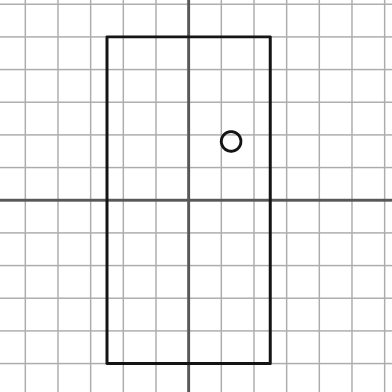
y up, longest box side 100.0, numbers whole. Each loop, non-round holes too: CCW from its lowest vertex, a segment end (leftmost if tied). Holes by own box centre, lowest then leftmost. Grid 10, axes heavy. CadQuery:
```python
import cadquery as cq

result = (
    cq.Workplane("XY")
    .moveTo(-25.0, -50.0)
    .lineTo(25.0, -50.0)
    .lineTo(25.0, 50.0)
    .lineTo(-25.0, 50.0)
    .close()
    .moveTo(13.0, 18.0)
    .circle(3.0)
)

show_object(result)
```